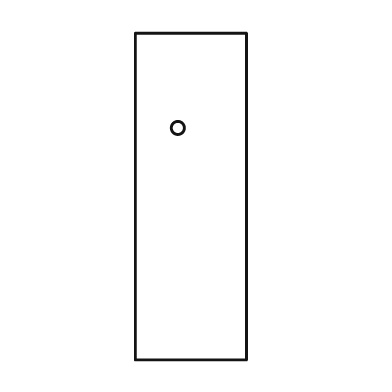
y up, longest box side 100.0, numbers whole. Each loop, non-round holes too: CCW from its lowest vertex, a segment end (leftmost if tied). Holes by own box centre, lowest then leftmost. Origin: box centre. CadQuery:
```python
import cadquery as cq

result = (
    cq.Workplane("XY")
    .moveTo(-17.0, -50.0)
    .lineTo(17.0, -50.0)
    .lineTo(17.0, 50.0)
    .lineTo(-17.0, 50.0)
    .close()
    .moveTo(-4.0, 21.0)
    .circle(2.0)
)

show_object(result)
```